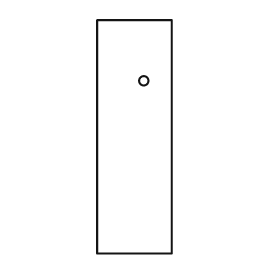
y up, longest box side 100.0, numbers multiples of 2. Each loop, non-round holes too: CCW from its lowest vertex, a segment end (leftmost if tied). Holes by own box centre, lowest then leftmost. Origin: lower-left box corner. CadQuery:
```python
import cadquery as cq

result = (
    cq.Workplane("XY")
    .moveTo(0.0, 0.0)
    .lineTo(32.0, 0.0)
    .lineTo(32.0, 100.0)
    .lineTo(0.0, 100.0)
    .close()
    .moveTo(20.0, 74.0)
    .circle(2.0)
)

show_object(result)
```